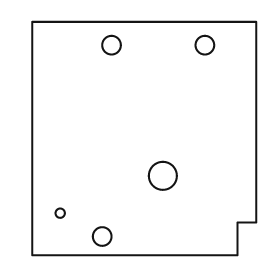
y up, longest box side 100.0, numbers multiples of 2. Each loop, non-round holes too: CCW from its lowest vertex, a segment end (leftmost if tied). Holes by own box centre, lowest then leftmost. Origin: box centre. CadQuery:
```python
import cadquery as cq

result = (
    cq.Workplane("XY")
    .moveTo(-48.0, -50.0)
    .lineTo(40.0, -50.0)
    .lineTo(40.0, -36.0)
    .lineTo(48.0, -36.0)
    .lineTo(48.0, 50.0)
    .lineTo(-48.0, 50.0)
    .close()
    .moveTo(-18.0, -42.0)
    .circle(4.0)
    .moveTo(-36.0, -32.0)
    .circle(2.0)
    .moveTo(8.0, -16.0)
    .circle(6.0)
    .moveTo(-14.0, 40.0)
    .circle(4.0)
    .moveTo(26.0, 40.0)
    .circle(4.0)
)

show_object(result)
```